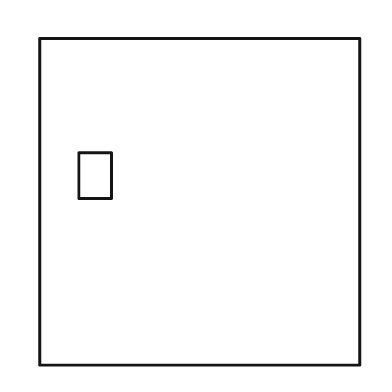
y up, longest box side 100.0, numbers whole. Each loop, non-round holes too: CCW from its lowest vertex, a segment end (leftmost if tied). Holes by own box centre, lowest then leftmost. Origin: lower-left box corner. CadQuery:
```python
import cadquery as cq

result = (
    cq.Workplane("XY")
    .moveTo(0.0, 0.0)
    .lineTo(98.0, 0.0)
    .lineTo(98.0, 100.0)
    .lineTo(0.0, 100.0)
    .close()
    .moveTo(12.0, 51.0)
    .lineTo(22.0, 51.0)
    .lineTo(22.0, 65.0)
    .lineTo(12.0, 65.0)
    .close()
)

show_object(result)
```